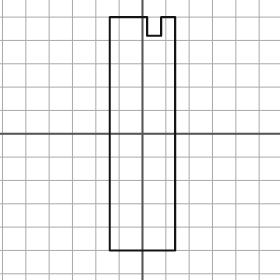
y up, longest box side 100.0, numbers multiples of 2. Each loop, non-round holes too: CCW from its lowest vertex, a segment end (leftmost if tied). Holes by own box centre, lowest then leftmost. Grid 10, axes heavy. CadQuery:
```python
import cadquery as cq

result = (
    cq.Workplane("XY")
    .moveTo(-14.0, -50.0)
    .lineTo(14.0, -50.0)
    .lineTo(14.0, 50.0)
    .lineTo(8.0, 50.0)
    .lineTo(8.0, 42.0)
    .lineTo(2.0, 42.0)
    .lineTo(2.0, 50.0)
    .lineTo(-14.0, 50.0)
    .close()
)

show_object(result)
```